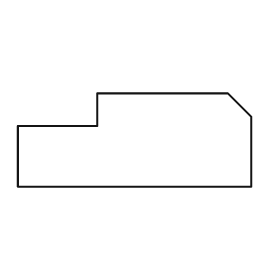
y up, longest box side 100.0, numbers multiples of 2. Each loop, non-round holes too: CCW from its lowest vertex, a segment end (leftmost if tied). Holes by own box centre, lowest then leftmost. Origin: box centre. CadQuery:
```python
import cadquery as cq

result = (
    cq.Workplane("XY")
    .moveTo(-50.0, -20.0)
    .lineTo(50.0, -20.0)
    .lineTo(50.0, 10.0)
    .lineTo(40.0, 20.0)
    .lineTo(-16.0, 20.0)
    .lineTo(-16.0, 6.0)
    .lineTo(-50.0, 6.0)
    .close()
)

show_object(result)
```